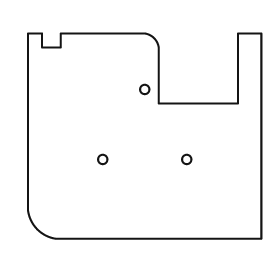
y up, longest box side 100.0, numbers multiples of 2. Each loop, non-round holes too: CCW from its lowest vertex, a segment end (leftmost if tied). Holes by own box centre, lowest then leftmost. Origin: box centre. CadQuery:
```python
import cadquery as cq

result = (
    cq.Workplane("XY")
    .moveTo(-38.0, -44.0)
    .lineTo(50.0, -44.0)
    .lineTo(50.0, 44.0)
    .lineTo(40.0, 44.0)
    .lineTo(40.0, 14.0)
    .lineTo(6.0, 14.0)
    .lineTo(6.0, 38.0)
    .threePointArc((4.0, 42.0), (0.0, 44.0))
    .lineTo(-36.0, 44.0)
    .lineTo(-36.0, 38.0)
    .lineTo(-44.0, 38.0)
    .lineTo(-44.0, 44.0)
    .lineTo(-50.0, 44.0)
    .lineTo(-50.0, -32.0)
    .threePointArc((-46.0, -40.0), (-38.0, -44.0))
    .close()
    .moveTo(-18.0, -10.0)
    .circle(2.0)
    .moveTo(18.0, -10.0)
    .circle(2.0)
    .moveTo(0.0, 20.0)
    .circle(2.0)
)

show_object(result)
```